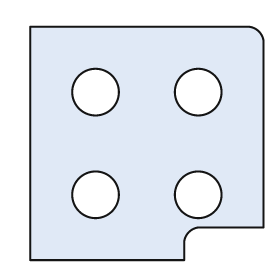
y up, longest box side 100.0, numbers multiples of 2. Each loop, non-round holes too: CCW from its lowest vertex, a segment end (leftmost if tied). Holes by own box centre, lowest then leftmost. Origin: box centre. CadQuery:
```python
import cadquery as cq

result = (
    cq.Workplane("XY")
    .moveTo(-50.0, -50.0)
    .lineTo(16.0, -50.0)
    .lineTo(16.0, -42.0)
    .threePointArc((18.0, -38.0), (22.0, -36.0))
    .lineTo(50.0, -36.0)
    .lineTo(50.0, 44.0)
    .threePointArc((48.0, 48.0), (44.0, 50.0))
    .lineTo(-50.0, 50.0)
    .close()
    .moveTo(-22.0, -22.0)
    .circle(10.0)
    .moveTo(22.0, -22.0)
    .circle(10.0)
    .moveTo(-22.0, 22.0)
    .circle(10.0)
    .moveTo(22.0, 22.0)
    .circle(10.0)
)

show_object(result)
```